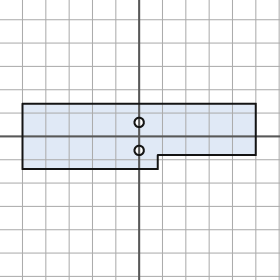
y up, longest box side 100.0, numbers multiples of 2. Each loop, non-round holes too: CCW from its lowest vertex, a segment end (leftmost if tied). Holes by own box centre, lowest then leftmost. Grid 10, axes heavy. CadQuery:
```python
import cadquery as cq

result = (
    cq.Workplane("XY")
    .moveTo(-50.0, -14.0)
    .lineTo(8.0, -14.0)
    .lineTo(8.0, -8.0)
    .lineTo(50.0, -8.0)
    .lineTo(50.0, 14.0)
    .lineTo(-50.0, 14.0)
    .close()
    .moveTo(0.0, -6.0)
    .circle(2.0)
    .moveTo(0.0, 6.0)
    .circle(2.0)
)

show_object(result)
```